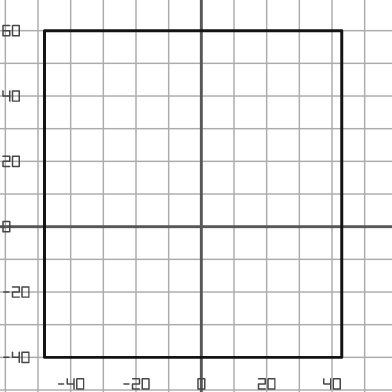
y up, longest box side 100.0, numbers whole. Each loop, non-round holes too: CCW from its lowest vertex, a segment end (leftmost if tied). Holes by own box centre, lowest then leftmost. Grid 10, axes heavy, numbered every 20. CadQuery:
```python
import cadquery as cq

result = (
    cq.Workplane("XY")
    .moveTo(-48.0, -40.0)
    .lineTo(43.0, -40.0)
    .lineTo(43.0, 60.0)
    .lineTo(-48.0, 60.0)
    .close()
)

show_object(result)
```